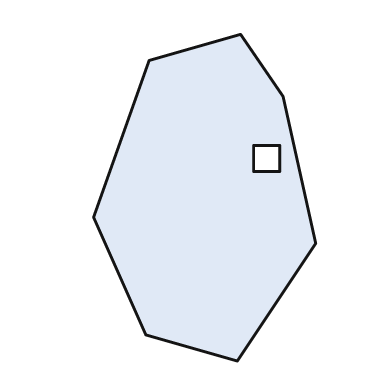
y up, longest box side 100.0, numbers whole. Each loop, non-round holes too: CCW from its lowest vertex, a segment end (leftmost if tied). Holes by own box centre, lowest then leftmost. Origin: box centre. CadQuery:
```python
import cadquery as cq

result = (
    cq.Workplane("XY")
    .moveTo(10.0, -50.0)
    .lineTo(34.0, -14.0)
    .lineTo(24.0, 31.0)
    .lineTo(11.0, 50.0)
    .lineTo(-17.0, 42.0)
    .lineTo(-34.0, -6.0)
    .lineTo(-18.0, -42.0)
    .close()
    .moveTo(15.0, 8.0)
    .lineTo(23.0, 8.0)
    .lineTo(23.0, 16.0)
    .lineTo(15.0, 16.0)
    .close()
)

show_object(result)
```